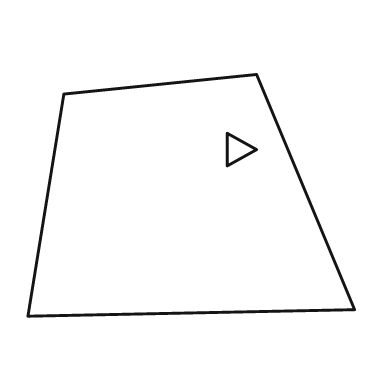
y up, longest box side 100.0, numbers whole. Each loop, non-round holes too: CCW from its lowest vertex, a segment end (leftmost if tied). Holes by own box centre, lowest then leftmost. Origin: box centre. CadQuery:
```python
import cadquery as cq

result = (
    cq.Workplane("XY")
    .moveTo(-50.0, -37.0)
    .lineTo(50.0, -35.0)
    .lineTo(20.0, 37.0)
    .lineTo(-39.0, 31.0)
    .close()
    .moveTo(11.0, 9.0)
    .lineTo(20.0, 14.0)
    .lineTo(11.0, 19.0)
    .close()
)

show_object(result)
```